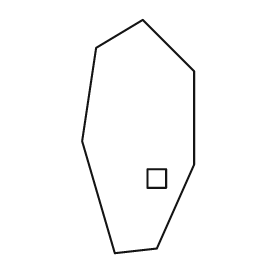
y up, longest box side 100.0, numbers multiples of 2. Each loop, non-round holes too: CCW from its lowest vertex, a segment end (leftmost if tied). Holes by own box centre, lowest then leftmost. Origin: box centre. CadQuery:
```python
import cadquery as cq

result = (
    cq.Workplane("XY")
    .moveTo(-10.0, -50.0)
    .lineTo(8.0, -48.0)
    .lineTo(24.0, -12.0)
    .lineTo(24.0, 28.0)
    .lineTo(2.0, 50.0)
    .lineTo(-18.0, 38.0)
    .lineTo(-24.0, -2.0)
    .close()
    .moveTo(4.0, -22.0)
    .lineTo(12.0, -22.0)
    .lineTo(12.0, -14.0)
    .lineTo(4.0, -14.0)
    .close()
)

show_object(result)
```